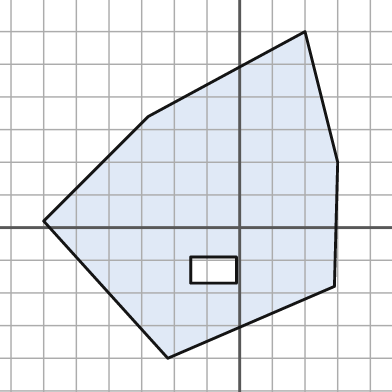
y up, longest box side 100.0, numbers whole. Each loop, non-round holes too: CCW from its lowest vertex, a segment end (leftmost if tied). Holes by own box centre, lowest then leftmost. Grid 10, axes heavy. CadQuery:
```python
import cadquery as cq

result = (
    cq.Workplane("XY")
    .moveTo(-22.0, -40.0)
    .lineTo(29.0, -18.0)
    .lineTo(30.0, 20.0)
    .lineTo(20.0, 60.0)
    .lineTo(-28.0, 34.0)
    .lineTo(-60.0, 2.0)
    .close()
    .moveTo(-15.0, -17.0)
    .lineTo(-1.0, -17.0)
    .lineTo(-1.0, -9.0)
    .lineTo(-15.0, -9.0)
    .close()
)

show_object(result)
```